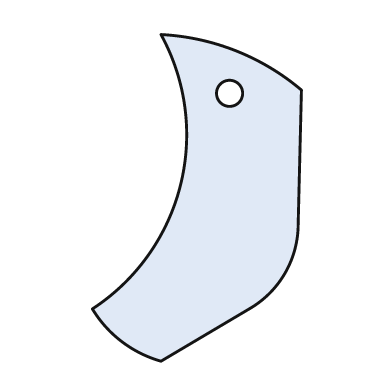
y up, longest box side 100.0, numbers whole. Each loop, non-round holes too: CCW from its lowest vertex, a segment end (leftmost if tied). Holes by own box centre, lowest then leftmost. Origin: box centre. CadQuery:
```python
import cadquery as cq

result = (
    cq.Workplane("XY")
    .moveTo(-11.0, -50.0)
    .lineTo(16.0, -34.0)
    .threePointArc((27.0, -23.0), (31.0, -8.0))
    .lineTo(32.0, 33.0)
    .threePointArc((12.0, 45.0), (-11.0, 50.0))
    .threePointArc((-5.0, 4.0), (-32.0, -34.0))
    .threePointArc((-23.0, -44.0), (-11.0, -50.0))
    .close()
    .moveTo(10.0, 32.0)
    .circle(4.0)
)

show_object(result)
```